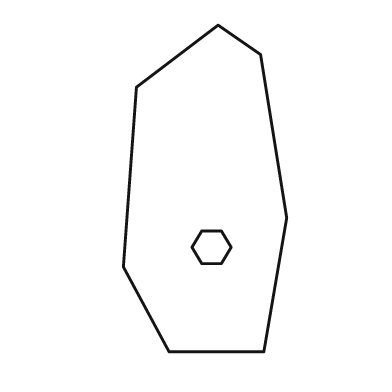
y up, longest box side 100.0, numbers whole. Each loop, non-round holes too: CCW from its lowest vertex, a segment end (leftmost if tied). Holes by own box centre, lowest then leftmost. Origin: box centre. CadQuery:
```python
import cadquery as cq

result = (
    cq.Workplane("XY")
    .moveTo(-11.0, -50.0)
    .lineTo(18.0, -50.0)
    .lineTo(25.0, -9.0)
    .lineTo(17.0, 41.0)
    .lineTo(4.0, 50.0)
    .lineTo(-21.0, 31.0)
    .lineTo(-25.0, -24.0)
    .close()
    .moveTo(-1.0, -23.0)
    .lineTo(5.0, -23.0)
    .lineTo(8.0, -18.0)
    .lineTo(5.0, -13.0)
    .lineTo(-1.0, -13.0)
    .lineTo(-4.0, -18.0)
    .close()
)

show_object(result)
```